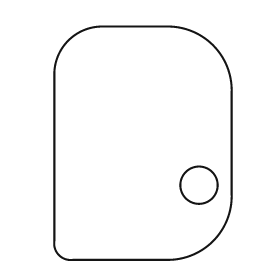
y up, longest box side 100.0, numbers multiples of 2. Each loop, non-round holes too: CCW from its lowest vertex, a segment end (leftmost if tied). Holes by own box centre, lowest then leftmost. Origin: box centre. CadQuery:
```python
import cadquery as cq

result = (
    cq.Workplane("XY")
    .moveTo(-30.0, -50.0)
    .lineTo(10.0, -50.0)
    .threePointArc((30.0, -42.0), (38.0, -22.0))
    .lineTo(38.0, 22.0)
    .threePointArc((30.0, 42.0), (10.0, 50.0))
    .lineTo(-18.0, 50.0)
    .threePointArc((-32.0, 44.0), (-38.0, 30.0))
    .lineTo(-38.0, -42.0)
    .threePointArc((-36.0, -48.0), (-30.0, -50.0))
    .close()
    .moveTo(24.0, -18.0)
    .circle(8.0)
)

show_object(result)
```